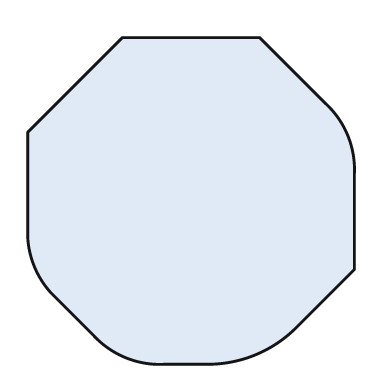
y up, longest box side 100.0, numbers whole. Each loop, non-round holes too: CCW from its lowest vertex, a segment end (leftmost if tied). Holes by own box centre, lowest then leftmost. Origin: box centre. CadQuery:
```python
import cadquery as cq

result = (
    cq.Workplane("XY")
    .moveTo(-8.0, -50.0)
    .lineTo(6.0, -50.0)
    .threePointArc((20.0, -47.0), (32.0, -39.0))
    .lineTo(50.0, -21.0)
    .lineTo(50.0, 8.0)
    .threePointArc((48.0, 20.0), (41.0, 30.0))
    .lineTo(21.0, 50.0)
    .lineTo(-21.0, 50.0)
    .lineTo(-50.0, 21.0)
    .lineTo(-50.0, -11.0)
    .threePointArc((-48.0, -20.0), (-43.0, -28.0))
    .lineTo(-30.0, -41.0)
    .threePointArc((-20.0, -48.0), (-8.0, -50.0))
    .close()
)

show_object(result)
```